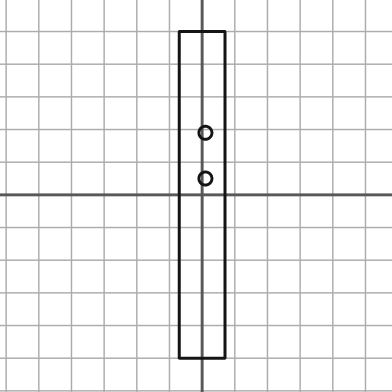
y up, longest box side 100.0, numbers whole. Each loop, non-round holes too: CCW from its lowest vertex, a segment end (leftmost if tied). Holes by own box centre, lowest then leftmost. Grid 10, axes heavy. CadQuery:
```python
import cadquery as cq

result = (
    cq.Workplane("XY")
    .moveTo(-7.0, -50.0)
    .lineTo(7.0, -50.0)
    .lineTo(7.0, 50.0)
    .lineTo(-7.0, 50.0)
    .close()
    .moveTo(1.0, 5.0)
    .circle(2.0)
    .moveTo(1.0, 19.0)
    .circle(2.0)
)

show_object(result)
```